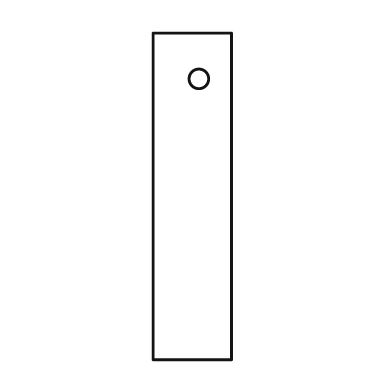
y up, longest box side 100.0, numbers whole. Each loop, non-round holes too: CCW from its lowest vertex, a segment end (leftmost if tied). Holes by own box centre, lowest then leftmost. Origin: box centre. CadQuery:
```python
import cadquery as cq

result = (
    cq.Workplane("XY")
    .moveTo(-12.0, -50.0)
    .lineTo(12.0, -50.0)
    .lineTo(12.0, 50.0)
    .lineTo(-12.0, 50.0)
    .close()
    .moveTo(2.0, 36.0)
    .circle(3.0)
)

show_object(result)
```